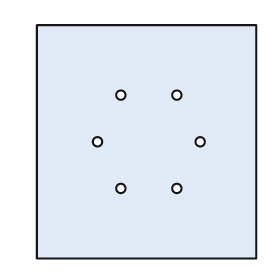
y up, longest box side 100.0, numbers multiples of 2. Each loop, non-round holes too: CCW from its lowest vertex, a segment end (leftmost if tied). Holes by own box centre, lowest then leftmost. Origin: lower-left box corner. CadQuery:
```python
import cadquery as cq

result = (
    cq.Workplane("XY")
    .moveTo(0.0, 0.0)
    .lineTo(94.0, 0.0)
    .lineTo(94.0, 100.0)
    .lineTo(0.0, 100.0)
    .close()
    .moveTo(36.0, 30.0)
    .circle(2.0)
    .moveTo(60.0, 30.0)
    .circle(2.0)
    .moveTo(26.0, 50.0)
    .circle(2.0)
    .moveTo(70.0, 50.0)
    .circle(2.0)
    .moveTo(36.0, 70.0)
    .circle(2.0)
    .moveTo(60.0, 70.0)
    .circle(2.0)
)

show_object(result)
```